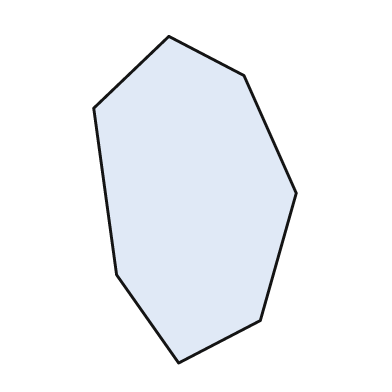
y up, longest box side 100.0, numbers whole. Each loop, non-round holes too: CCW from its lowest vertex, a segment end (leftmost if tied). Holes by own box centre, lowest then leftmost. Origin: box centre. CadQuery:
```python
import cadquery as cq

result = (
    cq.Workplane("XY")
    .moveTo(-5.0, -50.0)
    .lineTo(20.0, -37.0)
    .lineTo(31.0, 2.0)
    .lineTo(15.0, 38.0)
    .lineTo(-8.0, 50.0)
    .lineTo(-31.0, 28.0)
    .lineTo(-24.0, -23.0)
    .close()
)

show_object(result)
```